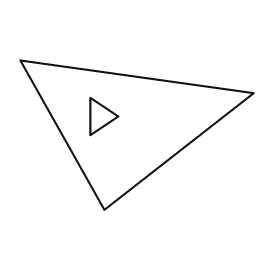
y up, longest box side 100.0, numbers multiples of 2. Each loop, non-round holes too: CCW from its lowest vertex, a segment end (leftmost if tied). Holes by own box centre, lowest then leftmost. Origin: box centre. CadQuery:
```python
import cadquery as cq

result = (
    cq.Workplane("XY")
    .moveTo(-14.0, -32.0)
    .lineTo(50.0, 18.0)
    .lineTo(-50.0, 32.0)
    .close()
    .moveTo(-20.0, 0.0)
    .lineTo(-8.0, 8.0)
    .lineTo(-20.0, 16.0)
    .close()
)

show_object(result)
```